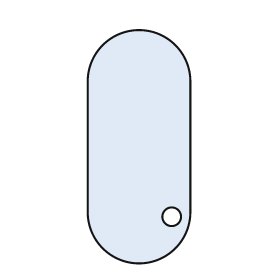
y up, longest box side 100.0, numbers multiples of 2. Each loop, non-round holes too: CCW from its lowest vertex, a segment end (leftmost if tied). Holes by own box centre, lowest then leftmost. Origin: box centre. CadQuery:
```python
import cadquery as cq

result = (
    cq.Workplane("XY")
    .moveTo(-22.0, -28.0)
    .threePointArc((0.0, -50.0), (22.0, -28.0))
    .lineTo(22.0, 28.0)
    .threePointArc((0.0, 50.0), (-22.0, 28.0))
    .close()
    .moveTo(14.0, -30.0)
    .circle(4.0)
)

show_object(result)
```